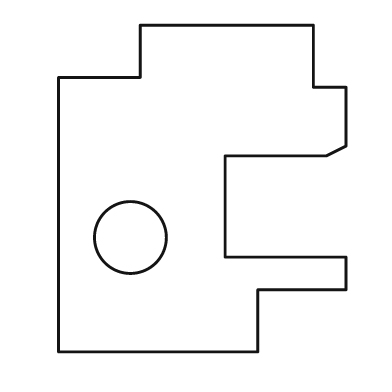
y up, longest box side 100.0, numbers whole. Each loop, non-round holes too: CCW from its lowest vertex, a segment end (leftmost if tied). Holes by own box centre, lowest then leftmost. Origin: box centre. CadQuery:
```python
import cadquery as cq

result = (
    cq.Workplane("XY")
    .moveTo(-44.0, -50.0)
    .lineTo(17.0, -50.0)
    .lineTo(17.0, -31.0)
    .lineTo(44.0, -31.0)
    .lineTo(44.0, -21.0)
    .lineTo(7.0, -21.0)
    .lineTo(7.0, 10.0)
    .lineTo(38.0, 10.0)
    .lineTo(44.0, 13.0)
    .lineTo(44.0, 31.0)
    .lineTo(34.0, 31.0)
    .lineTo(34.0, 50.0)
    .lineTo(-19.0, 50.0)
    .lineTo(-19.0, 34.0)
    .lineTo(-44.0, 34.0)
    .close()
    .moveTo(-22.0, -15.0)
    .circle(11.0)
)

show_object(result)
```